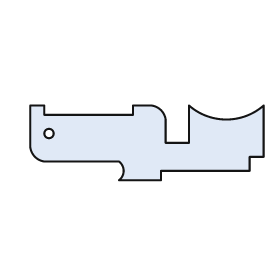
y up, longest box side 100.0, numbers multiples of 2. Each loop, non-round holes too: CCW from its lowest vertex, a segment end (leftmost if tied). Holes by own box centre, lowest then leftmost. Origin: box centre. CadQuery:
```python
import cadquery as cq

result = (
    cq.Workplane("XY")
    .moveTo(-12.0, -16.0)
    .lineTo(6.0, -16.0)
    .lineTo(6.0, -12.0)
    .lineTo(44.0, -12.0)
    .lineTo(44.0, -6.0)
    .lineTo(50.0, -6.0)
    .lineTo(50.0, 16.0)
    .threePointArc((34.0, 10.0), (18.0, 16.0))
    .lineTo(18.0, 0.0)
    .lineTo(8.0, 0.0)
    .lineTo(8.0, 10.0)
    .threePointArc((6.0, 14.0), (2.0, 16.0))
    .lineTo(-6.0, 16.0)
    .lineTo(-6.0, 12.0)
    .lineTo(-44.0, 12.0)
    .lineTo(-44.0, 16.0)
    .lineTo(-50.0, 16.0)
    .lineTo(-50.0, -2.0)
    .threePointArc((-48.0, -6.0), (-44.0, -8.0))
    .lineTo(-12.0, -8.0)
    .threePointArc((-10.0, -12.0), (-12.0, -16.0))
    .close()
    .moveTo(-42.0, 4.0)
    .circle(2.0)
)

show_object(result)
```